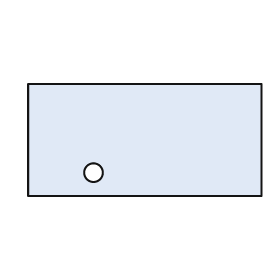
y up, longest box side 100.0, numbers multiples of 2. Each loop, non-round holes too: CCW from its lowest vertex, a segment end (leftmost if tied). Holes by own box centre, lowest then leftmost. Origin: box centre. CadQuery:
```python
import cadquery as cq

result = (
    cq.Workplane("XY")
    .moveTo(-50.0, -24.0)
    .lineTo(50.0, -24.0)
    .lineTo(50.0, 24.0)
    .lineTo(-50.0, 24.0)
    .close()
    .moveTo(-22.0, -14.0)
    .circle(4.0)
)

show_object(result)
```